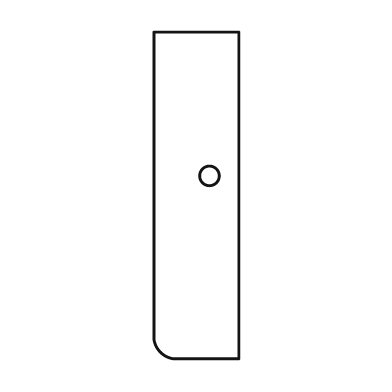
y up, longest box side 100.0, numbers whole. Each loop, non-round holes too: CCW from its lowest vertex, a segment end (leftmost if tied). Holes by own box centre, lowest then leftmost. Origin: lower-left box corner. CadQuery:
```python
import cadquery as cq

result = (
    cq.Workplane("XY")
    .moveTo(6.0, 0.0)
    .lineTo(26.0, 0.0)
    .lineTo(26.0, 100.0)
    .lineTo(0.0, 100.0)
    .lineTo(0.0, 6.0)
    .threePointArc((2.0, 2.0), (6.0, 0.0))
    .close()
    .moveTo(17.0, 56.0)
    .circle(3.0)
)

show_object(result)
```